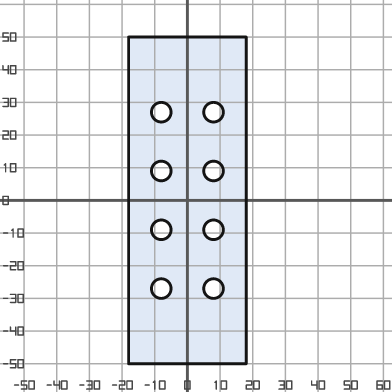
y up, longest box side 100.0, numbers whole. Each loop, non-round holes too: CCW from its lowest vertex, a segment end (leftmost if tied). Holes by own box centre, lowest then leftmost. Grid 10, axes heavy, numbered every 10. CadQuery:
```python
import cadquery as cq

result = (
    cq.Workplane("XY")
    .moveTo(-18.0, -50.0)
    .lineTo(18.0, -50.0)
    .lineTo(18.0, 50.0)
    .lineTo(-18.0, 50.0)
    .close()
    .moveTo(-8.0, -27.0)
    .circle(3.0)
    .moveTo(8.0, -27.0)
    .circle(3.0)
    .moveTo(-8.0, -9.0)
    .circle(3.0)
    .moveTo(8.0, -9.0)
    .circle(3.0)
    .moveTo(-8.0, 9.0)
    .circle(3.0)
    .moveTo(8.0, 9.0)
    .circle(3.0)
    .moveTo(-8.0, 27.0)
    .circle(3.0)
    .moveTo(8.0, 27.0)
    .circle(3.0)
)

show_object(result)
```